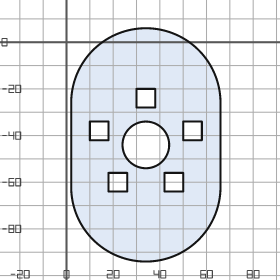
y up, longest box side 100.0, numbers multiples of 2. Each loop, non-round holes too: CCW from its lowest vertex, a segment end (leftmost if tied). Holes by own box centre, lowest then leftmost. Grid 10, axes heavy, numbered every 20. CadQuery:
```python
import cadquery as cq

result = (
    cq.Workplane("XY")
    .moveTo(2.0, -62.0)
    .threePointArc((34.0, -94.0), (66.0, -62.0))
    .lineTo(66.0, -26.0)
    .threePointArc((34.0, 6.0), (2.0, -26.0))
    .close()
    .moveTo(18.0, -64.0)
    .lineTo(26.0, -64.0)
    .lineTo(26.0, -56.0)
    .lineTo(18.0, -56.0)
    .close()
    .moveTo(42.0, -64.0)
    .lineTo(50.0, -64.0)
    .lineTo(50.0, -56.0)
    .lineTo(42.0, -56.0)
    .close()
    .moveTo(34.0, -44.0)
    .circle(10.0)
    .moveTo(10.0, -42.0)
    .lineTo(18.0, -42.0)
    .lineTo(18.0, -34.0)
    .lineTo(10.0, -34.0)
    .close()
    .moveTo(50.0, -42.0)
    .lineTo(58.0, -42.0)
    .lineTo(58.0, -34.0)
    .lineTo(50.0, -34.0)
    .close()
    .moveTo(30.0, -28.0)
    .lineTo(38.0, -28.0)
    .lineTo(38.0, -20.0)
    .lineTo(30.0, -20.0)
    .close()
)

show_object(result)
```